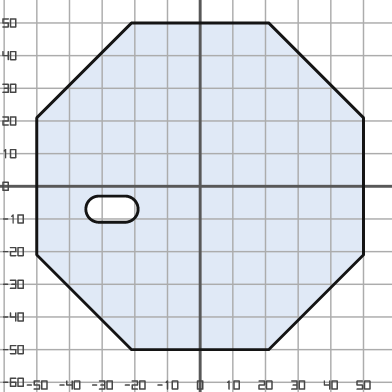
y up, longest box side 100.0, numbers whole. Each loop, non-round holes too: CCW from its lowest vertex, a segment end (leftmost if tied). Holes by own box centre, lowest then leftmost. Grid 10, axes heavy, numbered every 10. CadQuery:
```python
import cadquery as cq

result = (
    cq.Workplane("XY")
    .moveTo(-21.0, -50.0)
    .lineTo(21.0, -50.0)
    .lineTo(50.0, -21.0)
    .lineTo(50.0, 21.0)
    .lineTo(21.0, 50.0)
    .lineTo(-21.0, 50.0)
    .lineTo(-50.0, 21.0)
    .lineTo(-50.0, -21.0)
    .close()
    .moveTo(-31.0, -11.0)
    .lineTo(-23.0, -11.0)
    .threePointArc((-19.0, -7.0), (-23.0, -3.0))
    .lineTo(-31.0, -3.0)
    .threePointArc((-35.0, -7.0), (-31.0, -11.0))
    .close()
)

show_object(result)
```